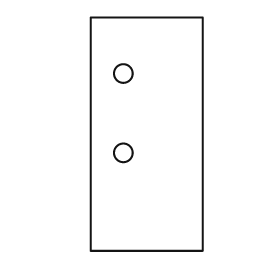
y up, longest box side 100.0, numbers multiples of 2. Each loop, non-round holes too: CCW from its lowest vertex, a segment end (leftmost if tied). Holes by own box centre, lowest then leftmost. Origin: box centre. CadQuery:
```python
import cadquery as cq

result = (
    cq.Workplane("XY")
    .moveTo(-24.0, -50.0)
    .lineTo(24.0, -50.0)
    .lineTo(24.0, 50.0)
    .lineTo(-24.0, 50.0)
    .close()
    .moveTo(-10.0, -8.0)
    .circle(4.0)
    .moveTo(-10.0, 26.0)
    .circle(4.0)
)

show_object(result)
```